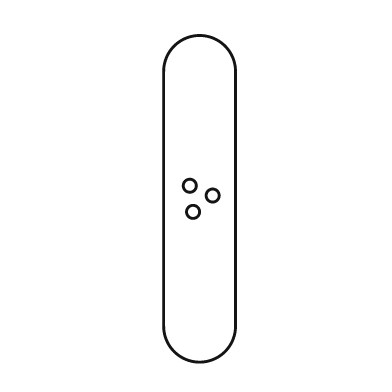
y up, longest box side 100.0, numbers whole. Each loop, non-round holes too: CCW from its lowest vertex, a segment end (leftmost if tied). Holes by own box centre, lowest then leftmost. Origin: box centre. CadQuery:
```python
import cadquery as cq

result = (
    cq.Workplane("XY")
    .moveTo(-11.0, -39.0)
    .threePointArc((0.0, -50.0), (11.0, -39.0))
    .lineTo(11.0, 39.0)
    .threePointArc((0.0, 50.0), (-11.0, 39.0))
    .close()
    .moveTo(-2.0, -4.0)
    .circle(2.0)
    .moveTo(4.0, 1.0)
    .circle(2.0)
    .moveTo(-3.0, 4.0)
    .circle(2.0)
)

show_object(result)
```